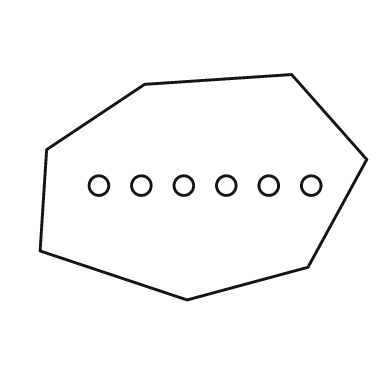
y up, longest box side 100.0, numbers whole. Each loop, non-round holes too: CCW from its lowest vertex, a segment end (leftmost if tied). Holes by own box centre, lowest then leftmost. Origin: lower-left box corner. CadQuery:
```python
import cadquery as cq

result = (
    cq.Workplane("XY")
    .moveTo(45.0, 0.0)
    .lineTo(82.0, 10.0)
    .lineTo(100.0, 43.0)
    .lineTo(77.0, 69.0)
    .lineTo(32.0, 66.0)
    .lineTo(2.0, 46.0)
    .lineTo(0.0, 15.0)
    .close()
    .moveTo(18.0, 35.0)
    .circle(3.0)
    .moveTo(31.0, 35.0)
    .circle(3.0)
    .moveTo(44.0, 35.0)
    .circle(3.0)
    .moveTo(57.0, 35.0)
    .circle(3.0)
    .moveTo(70.0, 35.0)
    .circle(3.0)
    .moveTo(83.0, 35.0)
    .circle(3.0)
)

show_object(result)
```